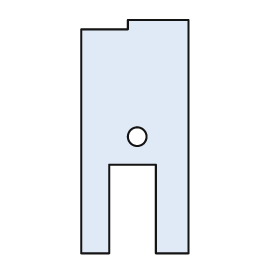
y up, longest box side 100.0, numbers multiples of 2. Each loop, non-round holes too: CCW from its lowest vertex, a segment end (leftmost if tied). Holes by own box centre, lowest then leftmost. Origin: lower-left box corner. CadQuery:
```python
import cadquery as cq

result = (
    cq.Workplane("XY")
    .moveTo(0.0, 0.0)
    .lineTo(12.0, 0.0)
    .lineTo(12.0, 38.0)
    .lineTo(32.0, 38.0)
    .lineTo(32.0, 0.0)
    .lineTo(46.0, 0.0)
    .lineTo(46.0, 100.0)
    .lineTo(20.0, 100.0)
    .lineTo(20.0, 96.0)
    .lineTo(0.0, 96.0)
    .close()
    .moveTo(24.0, 50.0)
    .circle(4.0)
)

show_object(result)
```